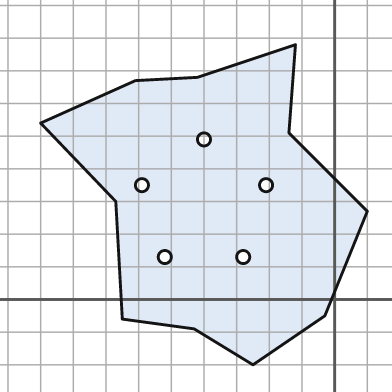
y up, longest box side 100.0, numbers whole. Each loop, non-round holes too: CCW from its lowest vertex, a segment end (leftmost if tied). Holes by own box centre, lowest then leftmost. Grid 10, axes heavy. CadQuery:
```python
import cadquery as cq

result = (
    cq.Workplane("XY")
    .moveTo(-25.0, -20.0)
    .lineTo(-3.0, -5.0)
    .lineTo(10.0, 27.0)
    .lineTo(-14.0, 51.0)
    .lineTo(-12.0, 78.0)
    .lineTo(-42.0, 68.0)
    .lineTo(-61.0, 67.0)
    .lineTo(-90.0, 54.0)
    .lineTo(-67.0, 30.0)
    .lineTo(-65.0, -6.0)
    .lineTo(-43.0, -9.0)
    .close()
    .moveTo(-52.0, 13.0)
    .circle(2.0)
    .moveTo(-28.0, 13.0)
    .circle(2.0)
    .moveTo(-59.0, 35.0)
    .circle(2.0)
    .moveTo(-21.0, 35.0)
    .circle(2.0)
    .moveTo(-40.0, 49.0)
    .circle(2.0)
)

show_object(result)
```